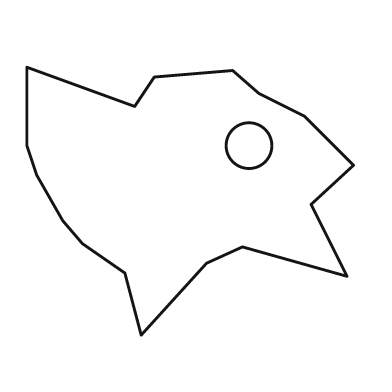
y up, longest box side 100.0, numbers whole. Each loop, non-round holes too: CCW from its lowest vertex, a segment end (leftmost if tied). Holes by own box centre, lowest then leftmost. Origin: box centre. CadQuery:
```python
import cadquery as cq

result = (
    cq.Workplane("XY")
    .moveTo(-15.0, -41.0)
    .lineTo(5.0, -19.0)
    .lineTo(16.0, -14.0)
    .lineTo(48.0, -23.0)
    .lineTo(37.0, -1.0)
    .lineTo(50.0, 11.0)
    .lineTo(35.0, 26.0)
    .lineTo(21.0, 33.0)
    .lineTo(13.0, 40.0)
    .lineTo(-11.0, 38.0)
    .lineTo(-17.0, 29.0)
    .lineTo(-50.0, 41.0)
    .lineTo(-50.0, 17.0)
    .lineTo(-47.0, 8.0)
    .lineTo(-39.0, -6.0)
    .lineTo(-33.0, -13.0)
    .lineTo(-20.0, -22.0)
    .close()
    .moveTo(18.0, 17.0)
    .circle(7.0)
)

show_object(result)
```